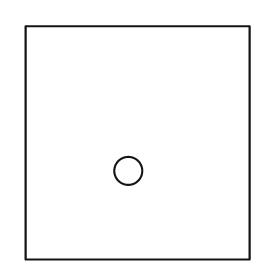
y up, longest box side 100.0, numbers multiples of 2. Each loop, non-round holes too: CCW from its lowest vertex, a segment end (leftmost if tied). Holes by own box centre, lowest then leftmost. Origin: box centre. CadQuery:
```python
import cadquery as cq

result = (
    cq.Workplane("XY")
    .moveTo(-48.0, -50.0)
    .lineTo(48.0, -50.0)
    .lineTo(48.0, 50.0)
    .lineTo(-48.0, 50.0)
    .close()
    .moveTo(-4.0, -12.0)
    .circle(6.0)
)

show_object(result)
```